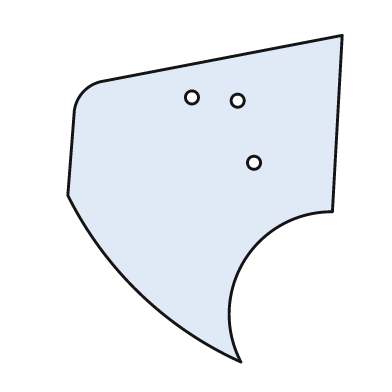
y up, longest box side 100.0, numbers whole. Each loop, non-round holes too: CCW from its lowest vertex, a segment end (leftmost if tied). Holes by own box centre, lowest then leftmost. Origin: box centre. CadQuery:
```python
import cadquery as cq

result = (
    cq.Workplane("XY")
    .moveTo(11.0, -50.0)
    .threePointArc((12.0, -19.0), (39.0, -4.0))
    .lineTo(42.0, 50.0)
    .lineTo(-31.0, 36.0)
    .threePointArc((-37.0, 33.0), (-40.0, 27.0))
    .lineTo(-42.0, 1.0)
    .threePointArc((-20.0, -29.0), (11.0, -50.0))
    .close()
    .moveTo(15.0, 11.0)
    .circle(2.0)
    .moveTo(10.0, 30.0)
    .circle(2.0)
    .moveTo(-4.0, 31.0)
    .circle(2.0)
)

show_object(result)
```